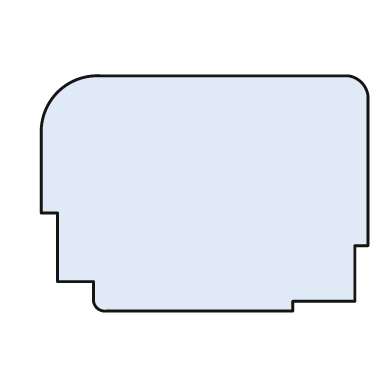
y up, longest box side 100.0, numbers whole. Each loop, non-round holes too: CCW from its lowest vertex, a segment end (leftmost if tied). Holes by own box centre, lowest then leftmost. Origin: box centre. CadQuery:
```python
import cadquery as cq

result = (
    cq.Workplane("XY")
    .moveTo(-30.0, -36.0)
    .lineTo(27.0, -36.0)
    .lineTo(27.0, -33.0)
    .lineTo(46.0, -33.0)
    .lineTo(46.0, -16.0)
    .lineTo(50.0, -16.0)
    .lineTo(50.0, 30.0)
    .threePointArc((48.0, 34.0), (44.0, 36.0))
    .lineTo(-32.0, 36.0)
    .threePointArc((-45.0, 31.0), (-50.0, 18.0))
    .lineTo(-50.0, -6.0)
    .lineTo(-45.0, -6.0)
    .lineTo(-45.0, -27.0)
    .lineTo(-34.0, -27.0)
    .lineTo(-34.0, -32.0)
    .threePointArc((-33.0, -35.0), (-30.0, -36.0))
    .close()
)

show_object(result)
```